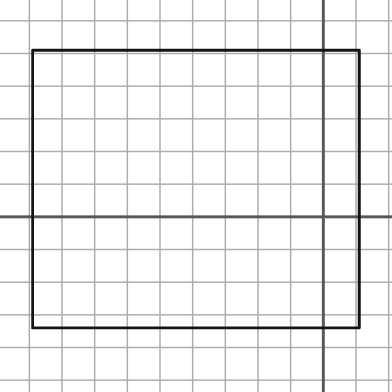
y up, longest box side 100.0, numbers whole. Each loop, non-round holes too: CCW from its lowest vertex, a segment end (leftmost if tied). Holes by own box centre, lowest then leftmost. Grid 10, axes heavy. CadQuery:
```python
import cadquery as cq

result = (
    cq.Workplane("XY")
    .moveTo(-89.0, -34.0)
    .lineTo(11.0, -34.0)
    .lineTo(11.0, 51.0)
    .lineTo(-89.0, 51.0)
    .close()
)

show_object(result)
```